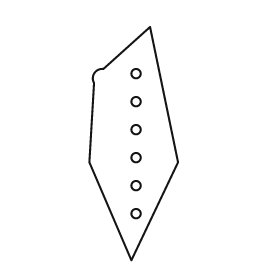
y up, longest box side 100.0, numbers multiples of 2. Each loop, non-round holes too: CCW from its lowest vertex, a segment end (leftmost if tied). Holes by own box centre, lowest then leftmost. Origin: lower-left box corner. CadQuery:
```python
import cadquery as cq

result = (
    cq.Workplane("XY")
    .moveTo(18.0, 0.0)
    .lineTo(38.0, 42.0)
    .lineTo(26.0, 100.0)
    .lineTo(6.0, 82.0)
    .threePointArc((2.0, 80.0), (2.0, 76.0))
    .lineTo(0.0, 42.0)
    .close()
    .moveTo(20.0, 20.0)
    .circle(2.0)
    .moveTo(20.0, 32.0)
    .circle(2.0)
    .moveTo(20.0, 44.0)
    .circle(2.0)
    .moveTo(20.0, 56.0)
    .circle(2.0)
    .moveTo(20.0, 68.0)
    .circle(2.0)
    .moveTo(20.0, 80.0)
    .circle(2.0)
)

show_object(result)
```